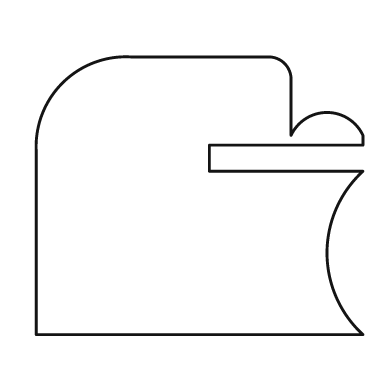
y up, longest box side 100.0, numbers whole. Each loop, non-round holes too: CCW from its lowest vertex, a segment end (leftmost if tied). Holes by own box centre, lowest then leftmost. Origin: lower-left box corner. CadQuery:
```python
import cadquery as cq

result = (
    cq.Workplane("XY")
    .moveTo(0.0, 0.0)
    .lineTo(100.0, 0.0)
    .threePointArc((89.0, 25.0), (100.0, 50.0))
    .lineTo(53.0, 50.0)
    .lineTo(53.0, 58.0)
    .lineTo(100.0, 58.0)
    .lineTo(100.0, 61.0)
    .threePointArc((89.0, 68.0), (78.0, 61.0))
    .lineTo(78.0, 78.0)
    .threePointArc((76.0, 83.0), (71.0, 85.0))
    .lineTo(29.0, 85.0)
    .threePointArc((8.0, 77.0), (0.0, 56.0))
    .close()
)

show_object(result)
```